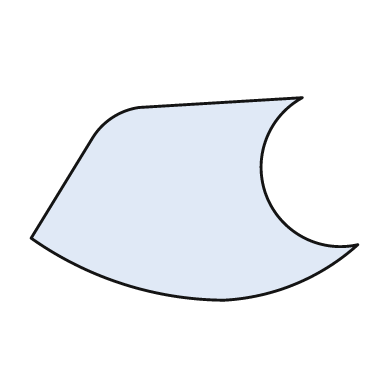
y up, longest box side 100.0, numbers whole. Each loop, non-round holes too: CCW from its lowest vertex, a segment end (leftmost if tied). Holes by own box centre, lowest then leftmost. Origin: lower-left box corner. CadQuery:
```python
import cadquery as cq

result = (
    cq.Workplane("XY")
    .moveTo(59.0, 0.0)
    .threePointArc((81.0, 5.0), (100.0, 17.0))
    .threePointArc((72.0, 32.0), (83.0, 62.0))
    .lineTo(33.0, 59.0)
    .threePointArc((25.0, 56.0), (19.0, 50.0))
    .lineTo(0.0, 19.0)
    .threePointArc((28.0, 5.0), (59.0, 0.0))
    .close()
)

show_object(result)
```